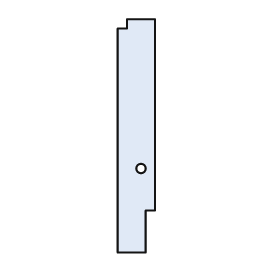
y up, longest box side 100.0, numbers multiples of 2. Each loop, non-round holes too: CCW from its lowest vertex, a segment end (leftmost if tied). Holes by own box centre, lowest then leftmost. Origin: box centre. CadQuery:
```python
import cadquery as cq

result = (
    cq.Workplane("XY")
    .moveTo(-8.0, -50.0)
    .lineTo(4.0, -50.0)
    .lineTo(4.0, -32.0)
    .lineTo(8.0, -32.0)
    .lineTo(8.0, 50.0)
    .lineTo(-4.0, 50.0)
    .lineTo(-4.0, 46.0)
    .lineTo(-8.0, 46.0)
    .close()
    .moveTo(2.0, -14.0)
    .circle(2.0)
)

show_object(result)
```